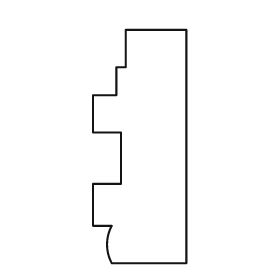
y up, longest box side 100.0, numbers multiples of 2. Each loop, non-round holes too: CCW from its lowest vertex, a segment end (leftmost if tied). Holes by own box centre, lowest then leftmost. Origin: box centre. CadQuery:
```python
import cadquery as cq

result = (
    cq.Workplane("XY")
    .moveTo(-12.0, -50.0)
    .lineTo(20.0, -50.0)
    .lineTo(20.0, 50.0)
    .lineTo(-6.0, 50.0)
    .lineTo(-6.0, 34.0)
    .lineTo(-10.0, 34.0)
    .lineTo(-10.0, 22.0)
    .lineTo(-20.0, 22.0)
    .lineTo(-20.0, 6.0)
    .lineTo(-8.0, 6.0)
    .lineTo(-8.0, -16.0)
    .lineTo(-20.0, -16.0)
    .lineTo(-20.0, -34.0)
    .lineTo(-12.0, -34.0)
    .threePointArc((-14.0, -42.0), (-12.0, -50.0))
    .close()
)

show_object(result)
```